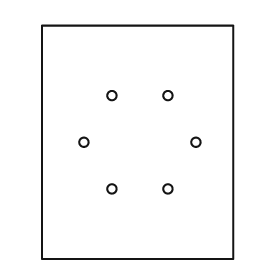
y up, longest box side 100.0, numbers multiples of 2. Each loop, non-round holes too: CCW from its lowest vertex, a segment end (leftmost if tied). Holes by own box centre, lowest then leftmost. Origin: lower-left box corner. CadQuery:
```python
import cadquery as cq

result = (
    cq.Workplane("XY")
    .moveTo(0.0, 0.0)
    .lineTo(82.0, 0.0)
    .lineTo(82.0, 100.0)
    .lineTo(0.0, 100.0)
    .close()
    .moveTo(30.0, 30.0)
    .circle(2.0)
    .moveTo(54.0, 30.0)
    .circle(2.0)
    .moveTo(18.0, 50.0)
    .circle(2.0)
    .moveTo(66.0, 50.0)
    .circle(2.0)
    .moveTo(30.0, 70.0)
    .circle(2.0)
    .moveTo(54.0, 70.0)
    .circle(2.0)
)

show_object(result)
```